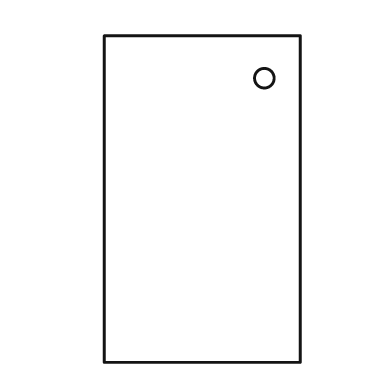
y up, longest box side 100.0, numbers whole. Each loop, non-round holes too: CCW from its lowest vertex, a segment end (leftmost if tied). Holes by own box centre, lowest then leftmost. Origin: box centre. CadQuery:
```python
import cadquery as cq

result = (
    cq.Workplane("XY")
    .moveTo(-30.0, -50.0)
    .lineTo(30.0, -50.0)
    .lineTo(30.0, 50.0)
    .lineTo(-30.0, 50.0)
    .close()
    .moveTo(19.0, 37.0)
    .circle(3.0)
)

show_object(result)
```